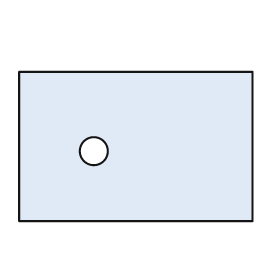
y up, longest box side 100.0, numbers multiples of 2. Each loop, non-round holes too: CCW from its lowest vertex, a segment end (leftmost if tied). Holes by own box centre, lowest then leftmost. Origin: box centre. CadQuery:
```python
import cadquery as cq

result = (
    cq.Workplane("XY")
    .moveTo(-50.0, -32.0)
    .lineTo(50.0, -32.0)
    .lineTo(50.0, 32.0)
    .lineTo(-50.0, 32.0)
    .close()
    .moveTo(-18.0, -2.0)
    .circle(6.0)
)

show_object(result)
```